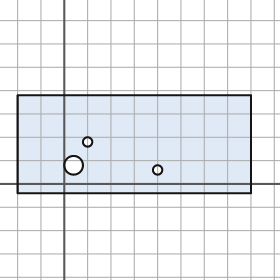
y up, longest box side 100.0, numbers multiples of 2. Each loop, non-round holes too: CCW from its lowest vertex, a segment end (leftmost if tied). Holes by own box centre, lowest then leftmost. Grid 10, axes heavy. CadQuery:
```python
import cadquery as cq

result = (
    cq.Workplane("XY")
    .moveTo(-20.0, -4.0)
    .lineTo(80.0, -4.0)
    .lineTo(80.0, 38.0)
    .lineTo(-20.0, 38.0)
    .close()
    .moveTo(40.0, 6.0)
    .circle(2.0)
    .moveTo(4.0, 8.0)
    .circle(4.0)
    .moveTo(10.0, 18.0)
    .circle(2.0)
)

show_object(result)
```